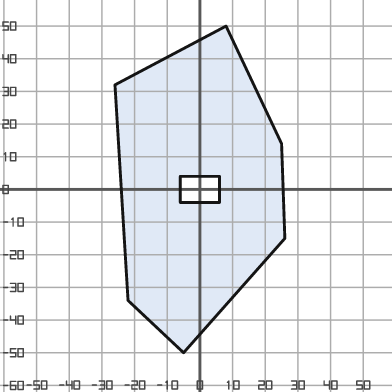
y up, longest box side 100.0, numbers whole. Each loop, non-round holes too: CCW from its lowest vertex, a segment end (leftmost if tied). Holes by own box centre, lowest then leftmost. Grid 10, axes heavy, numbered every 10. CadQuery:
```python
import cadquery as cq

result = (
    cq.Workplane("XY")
    .moveTo(-5.0, -50.0)
    .lineTo(26.0, -15.0)
    .lineTo(25.0, 14.0)
    .lineTo(8.0, 50.0)
    .lineTo(-26.0, 32.0)
    .lineTo(-22.0, -34.0)
    .close()
    .moveTo(-6.0, -4.0)
    .lineTo(6.0, -4.0)
    .lineTo(6.0, 4.0)
    .lineTo(-6.0, 4.0)
    .close()
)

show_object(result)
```